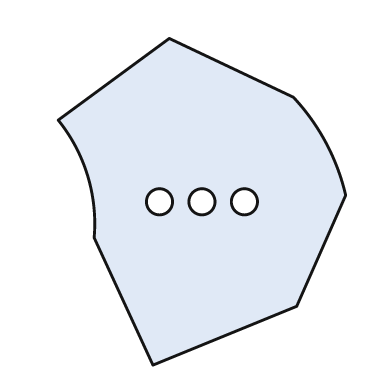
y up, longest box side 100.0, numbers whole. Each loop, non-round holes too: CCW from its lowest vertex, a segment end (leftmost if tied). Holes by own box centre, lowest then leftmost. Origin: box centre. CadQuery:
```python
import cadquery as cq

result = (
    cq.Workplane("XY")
    .moveTo(-15.0, -50.0)
    .lineTo(29.0, -32.0)
    .lineTo(44.0, 2.0)
    .threePointArc((38.0, 18.0), (28.0, 32.0))
    .lineTo(-10.0, 50.0)
    .lineTo(-44.0, 25.0)
    .threePointArc((-35.0, 8.0), (-33.0, -11.0))
    .close()
    .moveTo(-13.0, 0.0)
    .circle(4.0)
    .moveTo(0.0, 0.0)
    .circle(4.0)
    .moveTo(13.0, 0.0)
    .circle(4.0)
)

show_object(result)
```